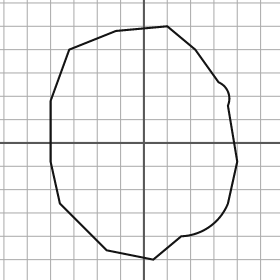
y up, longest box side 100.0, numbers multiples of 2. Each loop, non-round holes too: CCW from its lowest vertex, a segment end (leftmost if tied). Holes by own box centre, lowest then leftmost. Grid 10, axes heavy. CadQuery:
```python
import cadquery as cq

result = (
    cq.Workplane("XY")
    .moveTo(4.0, -50.0)
    .lineTo(16.0, -40.0)
    .threePointArc((28.0, -36.0), (36.0, -26.0))
    .lineTo(40.0, -8.0)
    .lineTo(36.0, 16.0)
    .threePointArc((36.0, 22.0), (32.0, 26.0))
    .lineTo(22.0, 40.0)
    .lineTo(10.0, 50.0)
    .lineTo(-12.0, 48.0)
    .lineTo(-32.0, 40.0)
    .lineTo(-40.0, 18.0)
    .lineTo(-40.0, -8.0)
    .lineTo(-36.0, -26.0)
    .lineTo(-16.0, -46.0)
    .close()
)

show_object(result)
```